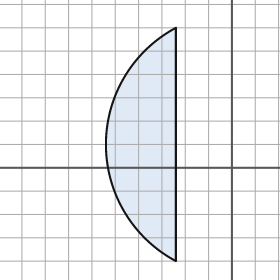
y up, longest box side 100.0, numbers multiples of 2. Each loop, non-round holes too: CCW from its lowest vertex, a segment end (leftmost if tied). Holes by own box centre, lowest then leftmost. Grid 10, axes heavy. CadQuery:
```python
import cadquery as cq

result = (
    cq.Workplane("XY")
    .moveTo(-24.0, -40.0)
    .lineTo(-24.0, 60.0)
    .threePointArc((-54.0, 10.0), (-24.0, -40.0))
    .close()
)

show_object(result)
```